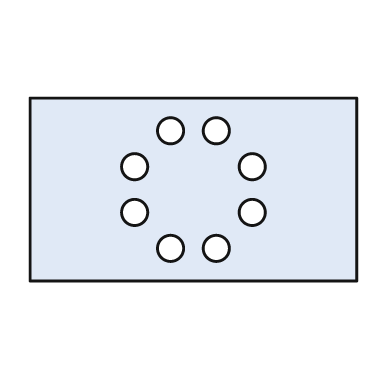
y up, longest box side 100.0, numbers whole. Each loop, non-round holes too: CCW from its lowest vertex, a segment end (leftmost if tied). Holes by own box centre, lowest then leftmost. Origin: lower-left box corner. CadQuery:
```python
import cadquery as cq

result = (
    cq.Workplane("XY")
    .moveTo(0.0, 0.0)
    .lineTo(100.0, 0.0)
    .lineTo(100.0, 56.0)
    .lineTo(0.0, 56.0)
    .close()
    .moveTo(43.0, 10.0)
    .circle(4.0)
    .moveTo(57.0, 10.0)
    .circle(4.0)
    .moveTo(32.0, 21.0)
    .circle(4.0)
    .moveTo(68.0, 21.0)
    .circle(4.0)
    .moveTo(32.0, 35.0)
    .circle(4.0)
    .moveTo(68.0, 35.0)
    .circle(4.0)
    .moveTo(43.0, 46.0)
    .circle(4.0)
    .moveTo(57.0, 46.0)
    .circle(4.0)
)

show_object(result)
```